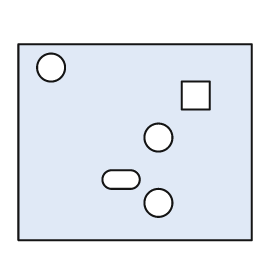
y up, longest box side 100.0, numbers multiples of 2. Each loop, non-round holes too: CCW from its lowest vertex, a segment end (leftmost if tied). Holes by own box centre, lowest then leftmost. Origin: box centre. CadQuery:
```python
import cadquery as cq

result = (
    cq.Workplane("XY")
    .moveTo(-50.0, -42.0)
    .lineTo(50.0, -42.0)
    .lineTo(50.0, 42.0)
    .lineTo(-50.0, 42.0)
    .close()
    .moveTo(10.0, -26.0)
    .circle(6.0)
    .moveTo(-10.0, -20.0)
    .lineTo(-2.0, -20.0)
    .threePointArc((2.0, -16.0), (-2.0, -12.0))
    .lineTo(-10.0, -12.0)
    .threePointArc((-14.0, -16.0), (-10.0, -20.0))
    .close()
    .moveTo(10.0, 2.0)
    .circle(6.0)
    .moveTo(20.0, 14.0)
    .lineTo(32.0, 14.0)
    .lineTo(32.0, 26.0)
    .lineTo(20.0, 26.0)
    .close()
    .moveTo(-36.0, 32.0)
    .circle(6.0)
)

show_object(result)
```